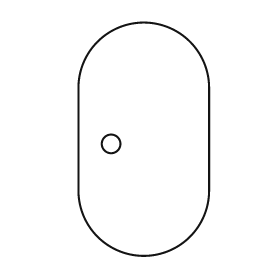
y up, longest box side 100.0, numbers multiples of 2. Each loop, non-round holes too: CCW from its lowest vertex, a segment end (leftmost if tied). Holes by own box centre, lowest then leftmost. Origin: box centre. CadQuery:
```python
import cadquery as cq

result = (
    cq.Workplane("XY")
    .moveTo(-28.0, -22.0)
    .threePointArc((0.0, -50.0), (28.0, -22.0))
    .lineTo(28.0, 22.0)
    .threePointArc((0.0, 50.0), (-28.0, 22.0))
    .close()
    .moveTo(-14.0, -2.0)
    .circle(4.0)
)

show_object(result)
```